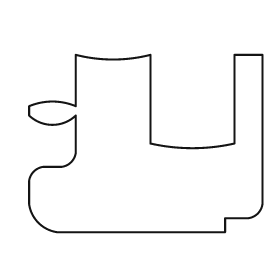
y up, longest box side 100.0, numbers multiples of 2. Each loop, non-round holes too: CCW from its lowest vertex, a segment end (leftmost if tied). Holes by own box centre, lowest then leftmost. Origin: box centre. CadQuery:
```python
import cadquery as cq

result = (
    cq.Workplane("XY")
    .moveTo(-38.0, -38.0)
    .lineTo(34.0, -38.0)
    .lineTo(34.0, -32.0)
    .lineTo(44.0, -32.0)
    .threePointArc((48.0, -30.0), (50.0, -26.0))
    .lineTo(50.0, 38.0)
    .lineTo(38.0, 38.0)
    .lineTo(38.0, 0.0)
    .threePointArc((20.0, -2.0), (2.0, 0.0))
    .lineTo(2.0, 38.0)
    .threePointArc((-14.0, 36.0), (-30.0, 38.0))
    .lineTo(-30.0, 16.0)
    .threePointArc((-40.0, 18.0), (-50.0, 16.0))
    .lineTo(-50.0, 12.0)
    .threePointArc((-40.0, 8.0), (-30.0, 12.0))
    .lineTo(-30.0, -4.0)
    .threePointArc((-32.0, -8.0), (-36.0, -10.0))
    .lineTo(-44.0, -10.0)
    .threePointArc((-48.0, -12.0), (-50.0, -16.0))
    .lineTo(-50.0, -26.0)
    .threePointArc((-46.0, -34.0), (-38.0, -38.0))
    .close()
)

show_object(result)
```